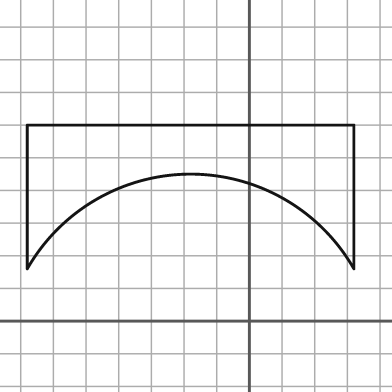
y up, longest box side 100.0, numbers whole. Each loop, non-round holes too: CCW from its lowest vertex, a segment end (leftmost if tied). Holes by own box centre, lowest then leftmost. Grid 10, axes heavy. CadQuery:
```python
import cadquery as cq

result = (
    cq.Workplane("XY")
    .moveTo(-68.0, 16.0)
    .threePointArc((-18.0, 45.0), (32.0, 16.0))
    .lineTo(32.0, 60.0)
    .lineTo(-68.0, 60.0)
    .close()
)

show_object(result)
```